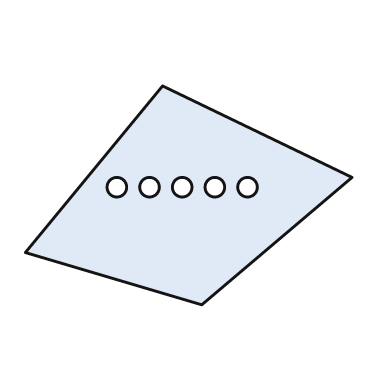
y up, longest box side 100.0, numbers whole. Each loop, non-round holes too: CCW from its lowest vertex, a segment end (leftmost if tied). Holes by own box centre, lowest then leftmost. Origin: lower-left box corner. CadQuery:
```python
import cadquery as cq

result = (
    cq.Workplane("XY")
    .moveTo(54.0, 0.0)
    .lineTo(100.0, 39.0)
    .lineTo(42.0, 67.0)
    .lineTo(0.0, 16.0)
    .close()
    .moveTo(28.0, 36.0)
    .circle(3.0)
    .moveTo(38.0, 36.0)
    .circle(3.0)
    .moveTo(48.0, 36.0)
    .circle(3.0)
    .moveTo(58.0, 36.0)
    .circle(3.0)
    .moveTo(68.0, 36.0)
    .circle(3.0)
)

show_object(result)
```